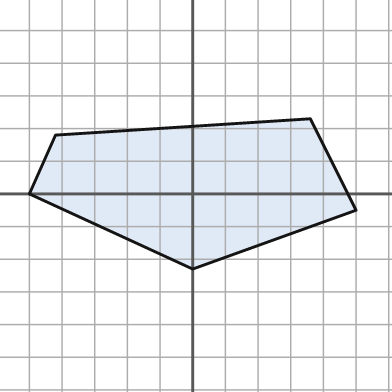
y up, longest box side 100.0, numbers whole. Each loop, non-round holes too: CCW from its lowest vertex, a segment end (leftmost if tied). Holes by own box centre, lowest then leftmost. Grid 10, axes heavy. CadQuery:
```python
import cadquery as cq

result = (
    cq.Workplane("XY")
    .moveTo(0.0, -23.0)
    .lineTo(50.0, -5.0)
    .lineTo(36.0, 23.0)
    .lineTo(-42.0, 18.0)
    .lineTo(-50.0, 0.0)
    .close()
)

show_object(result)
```